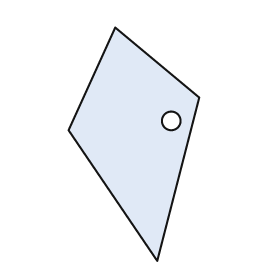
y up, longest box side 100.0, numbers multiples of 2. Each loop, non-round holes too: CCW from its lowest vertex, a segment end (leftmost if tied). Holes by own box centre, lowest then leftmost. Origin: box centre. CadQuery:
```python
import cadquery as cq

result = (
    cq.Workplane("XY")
    .moveTo(10.0, -50.0)
    .lineTo(28.0, 20.0)
    .lineTo(-8.0, 50.0)
    .lineTo(-28.0, 6.0)
    .close()
    .moveTo(16.0, 10.0)
    .circle(4.0)
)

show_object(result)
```